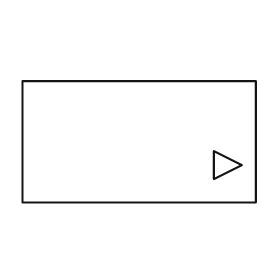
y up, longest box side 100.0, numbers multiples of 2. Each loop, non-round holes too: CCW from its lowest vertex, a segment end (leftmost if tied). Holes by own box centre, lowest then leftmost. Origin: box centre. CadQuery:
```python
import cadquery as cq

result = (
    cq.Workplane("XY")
    .moveTo(-50.0, -26.0)
    .lineTo(50.0, -26.0)
    .lineTo(50.0, 26.0)
    .lineTo(-50.0, 26.0)
    .close()
    .moveTo(32.0, -16.0)
    .lineTo(44.0, -10.0)
    .lineTo(32.0, -4.0)
    .close()
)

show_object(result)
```